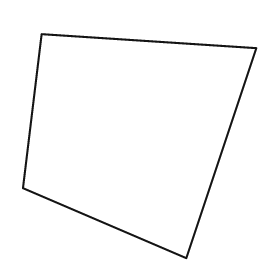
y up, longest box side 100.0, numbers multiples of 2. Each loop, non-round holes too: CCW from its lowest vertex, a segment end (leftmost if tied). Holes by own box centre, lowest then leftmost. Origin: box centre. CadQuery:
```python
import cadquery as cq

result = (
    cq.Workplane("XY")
    .moveTo(20.0, -48.0)
    .lineTo(50.0, 42.0)
    .lineTo(-42.0, 48.0)
    .lineTo(-50.0, -18.0)
    .close()
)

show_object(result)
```